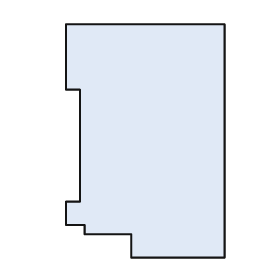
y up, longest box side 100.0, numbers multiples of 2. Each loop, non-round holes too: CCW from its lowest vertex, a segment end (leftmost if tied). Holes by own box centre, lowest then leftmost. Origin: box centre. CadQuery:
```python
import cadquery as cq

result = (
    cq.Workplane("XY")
    .moveTo(-6.0, -50.0)
    .lineTo(34.0, -50.0)
    .lineTo(34.0, 50.0)
    .lineTo(-34.0, 50.0)
    .lineTo(-34.0, 22.0)
    .lineTo(-28.0, 22.0)
    .lineTo(-28.0, -26.0)
    .lineTo(-34.0, -26.0)
    .lineTo(-34.0, -36.0)
    .lineTo(-26.0, -36.0)
    .lineTo(-26.0, -40.0)
    .lineTo(-6.0, -40.0)
    .close()
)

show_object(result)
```